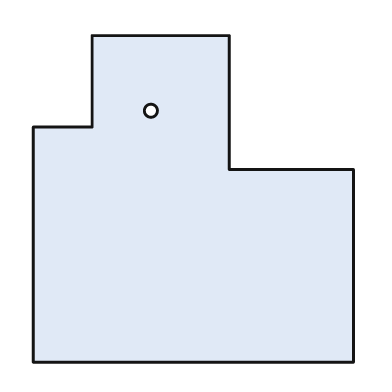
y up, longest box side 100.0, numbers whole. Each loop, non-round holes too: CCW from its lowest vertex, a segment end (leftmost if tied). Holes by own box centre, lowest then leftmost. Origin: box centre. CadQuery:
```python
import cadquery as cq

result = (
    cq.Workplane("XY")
    .moveTo(-49.0, -50.0)
    .lineTo(49.0, -50.0)
    .lineTo(49.0, 9.0)
    .lineTo(11.0, 9.0)
    .lineTo(11.0, 50.0)
    .lineTo(-31.0, 50.0)
    .lineTo(-31.0, 22.0)
    .lineTo(-49.0, 22.0)
    .close()
    .moveTo(-13.0, 27.0)
    .circle(2.0)
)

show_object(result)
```